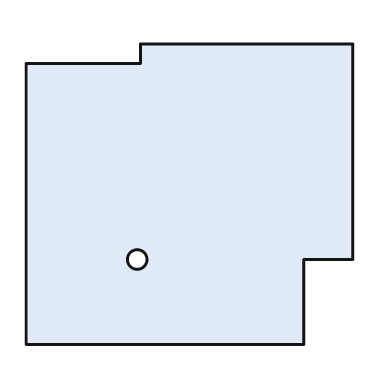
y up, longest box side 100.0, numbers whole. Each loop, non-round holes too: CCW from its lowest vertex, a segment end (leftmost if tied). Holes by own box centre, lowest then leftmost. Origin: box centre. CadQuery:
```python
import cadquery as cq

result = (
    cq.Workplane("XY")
    .moveTo(-50.0, -46.0)
    .lineTo(35.0, -46.0)
    .lineTo(35.0, -20.0)
    .lineTo(50.0, -20.0)
    .lineTo(50.0, 46.0)
    .lineTo(-15.0, 46.0)
    .lineTo(-15.0, 40.0)
    .lineTo(-50.0, 40.0)
    .close()
    .moveTo(-16.0, -20.0)
    .circle(3.0)
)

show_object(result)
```